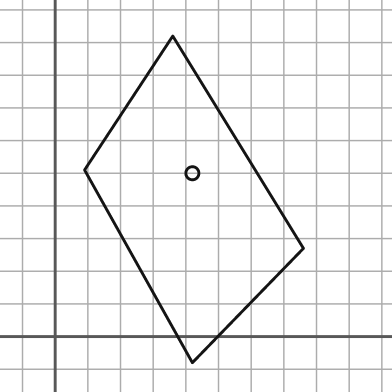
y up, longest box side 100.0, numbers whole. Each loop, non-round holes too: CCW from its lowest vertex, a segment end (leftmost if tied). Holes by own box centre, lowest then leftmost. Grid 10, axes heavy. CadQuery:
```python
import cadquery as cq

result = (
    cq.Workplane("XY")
    .moveTo(42.0, -8.0)
    .lineTo(76.0, 27.0)
    .lineTo(36.0, 92.0)
    .lineTo(9.0, 51.0)
    .close()
    .moveTo(42.0, 50.0)
    .circle(2.0)
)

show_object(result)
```